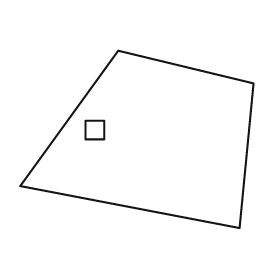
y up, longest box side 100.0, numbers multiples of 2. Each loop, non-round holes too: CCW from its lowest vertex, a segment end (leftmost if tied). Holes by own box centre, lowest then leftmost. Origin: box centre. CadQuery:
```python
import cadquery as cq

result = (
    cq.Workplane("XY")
    .moveTo(44.0, -38.0)
    .lineTo(50.0, 24.0)
    .lineTo(-8.0, 38.0)
    .lineTo(-50.0, -20.0)
    .close()
    .moveTo(-22.0, 0.0)
    .lineTo(-14.0, 0.0)
    .lineTo(-14.0, 8.0)
    .lineTo(-22.0, 8.0)
    .close()
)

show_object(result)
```